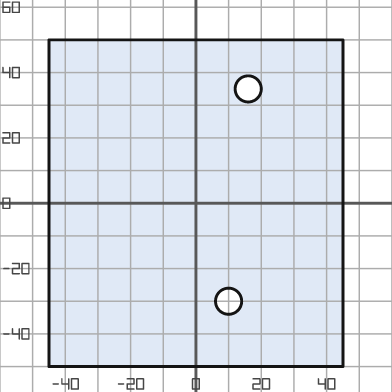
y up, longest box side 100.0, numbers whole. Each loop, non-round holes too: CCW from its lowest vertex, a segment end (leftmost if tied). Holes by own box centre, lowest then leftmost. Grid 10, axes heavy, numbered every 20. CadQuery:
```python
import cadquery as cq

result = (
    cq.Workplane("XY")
    .moveTo(-45.0, -50.0)
    .lineTo(45.0, -50.0)
    .lineTo(45.0, 50.0)
    .lineTo(-45.0, 50.0)
    .close()
    .moveTo(10.0, -30.0)
    .circle(4.0)
    .moveTo(16.0, 35.0)
    .circle(4.0)
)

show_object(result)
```